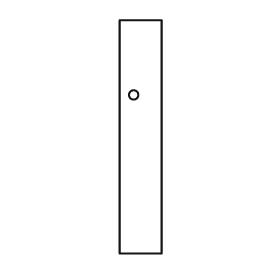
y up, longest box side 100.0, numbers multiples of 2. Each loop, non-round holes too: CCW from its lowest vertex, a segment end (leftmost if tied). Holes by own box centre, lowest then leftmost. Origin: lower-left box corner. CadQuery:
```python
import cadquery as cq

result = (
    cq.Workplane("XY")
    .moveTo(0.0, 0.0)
    .lineTo(18.0, 0.0)
    .lineTo(18.0, 100.0)
    .lineTo(0.0, 100.0)
    .close()
    .moveTo(6.0, 68.0)
    .circle(2.0)
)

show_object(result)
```